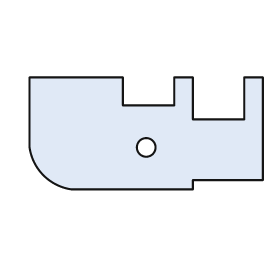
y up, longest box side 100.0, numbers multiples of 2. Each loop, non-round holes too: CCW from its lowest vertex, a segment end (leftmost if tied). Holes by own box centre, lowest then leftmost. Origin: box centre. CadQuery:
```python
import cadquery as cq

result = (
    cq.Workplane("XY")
    .moveTo(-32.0, -24.0)
    .lineTo(20.0, -24.0)
    .lineTo(20.0, -20.0)
    .lineTo(50.0, -20.0)
    .lineTo(50.0, 24.0)
    .lineTo(42.0, 24.0)
    .lineTo(42.0, 6.0)
    .lineTo(20.0, 6.0)
    .lineTo(20.0, 24.0)
    .lineTo(12.0, 24.0)
    .lineTo(12.0, 12.0)
    .lineTo(-10.0, 12.0)
    .lineTo(-10.0, 24.0)
    .lineTo(-50.0, 24.0)
    .lineTo(-50.0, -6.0)
    .threePointArc((-44.0, -18.0), (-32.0, -24.0))
    .close()
    .moveTo(0.0, -6.0)
    .circle(4.0)
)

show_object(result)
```